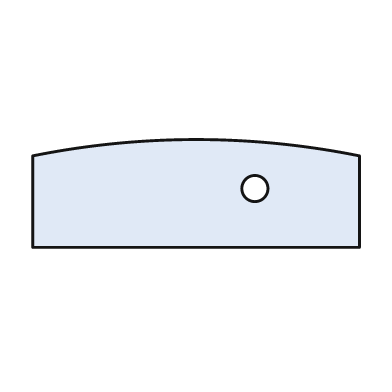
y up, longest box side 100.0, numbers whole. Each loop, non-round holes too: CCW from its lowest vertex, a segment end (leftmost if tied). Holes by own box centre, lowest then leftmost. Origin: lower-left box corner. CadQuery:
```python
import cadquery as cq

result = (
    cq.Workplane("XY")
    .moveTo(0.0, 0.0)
    .lineTo(100.0, 0.0)
    .lineTo(100.0, 28.0)
    .threePointArc((50.0, 33.0), (0.0, 28.0))
    .close()
    .moveTo(68.0, 18.0)
    .circle(4.0)
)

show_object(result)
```